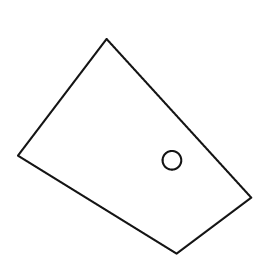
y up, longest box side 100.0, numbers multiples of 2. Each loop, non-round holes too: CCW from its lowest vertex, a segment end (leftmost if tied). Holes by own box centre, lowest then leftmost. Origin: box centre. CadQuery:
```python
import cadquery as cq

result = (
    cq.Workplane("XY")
    .moveTo(18.0, -46.0)
    .lineTo(50.0, -22.0)
    .lineTo(-12.0, 46.0)
    .lineTo(-50.0, -4.0)
    .close()
    .moveTo(16.0, -6.0)
    .circle(4.0)
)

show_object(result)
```